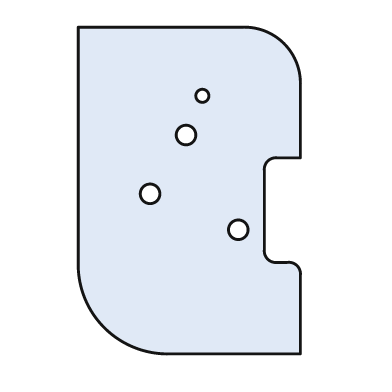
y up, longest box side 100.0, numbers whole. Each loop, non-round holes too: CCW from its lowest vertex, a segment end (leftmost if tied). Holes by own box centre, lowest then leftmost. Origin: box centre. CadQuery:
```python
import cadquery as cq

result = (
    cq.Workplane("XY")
    .moveTo(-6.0, -50.0)
    .lineTo(34.0, -50.0)
    .lineTo(34.0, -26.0)
    .threePointArc((33.0, -23.0), (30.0, -22.0))
    .lineTo(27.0, -22.0)
    .threePointArc((24.0, -21.0), (23.0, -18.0))
    .lineTo(23.0, 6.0)
    .threePointArc((24.0, 9.0), (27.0, 10.0))
    .lineTo(34.0, 10.0)
    .lineTo(34.0, 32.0)
    .threePointArc((29.0, 45.0), (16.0, 50.0))
    .lineTo(-34.0, 50.0)
    .lineTo(-34.0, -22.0)
    .threePointArc((-26.0, -42.0), (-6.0, -50.0))
    .close()
    .moveTo(15.0, -12.0)
    .circle(3.0)
    .moveTo(-12.0, -1.0)
    .circle(3.0)
    .moveTo(-1.0, 17.0)
    .circle(3.0)
    .moveTo(4.0, 29.0)
    .circle(2.0)
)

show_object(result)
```